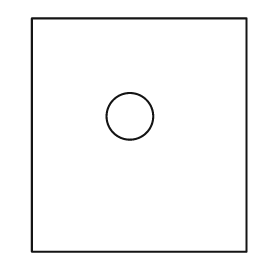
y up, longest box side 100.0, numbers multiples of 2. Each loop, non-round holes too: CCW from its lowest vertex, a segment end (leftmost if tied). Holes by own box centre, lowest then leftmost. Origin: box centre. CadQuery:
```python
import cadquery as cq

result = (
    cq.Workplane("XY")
    .moveTo(-46.0, -50.0)
    .lineTo(46.0, -50.0)
    .lineTo(46.0, 50.0)
    .lineTo(-46.0, 50.0)
    .close()
    .moveTo(-4.0, 8.0)
    .circle(10.0)
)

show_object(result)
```